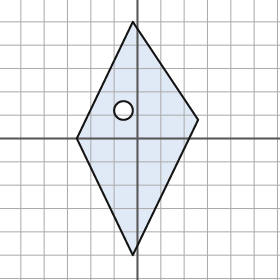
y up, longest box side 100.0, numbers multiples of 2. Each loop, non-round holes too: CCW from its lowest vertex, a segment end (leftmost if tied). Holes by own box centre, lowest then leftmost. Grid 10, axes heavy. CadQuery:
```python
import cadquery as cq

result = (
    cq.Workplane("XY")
    .moveTo(-2.0, -50.0)
    .lineTo(26.0, 8.0)
    .lineTo(-2.0, 50.0)
    .lineTo(-26.0, 0.0)
    .close()
    .moveTo(-6.0, 12.0)
    .circle(4.0)
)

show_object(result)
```